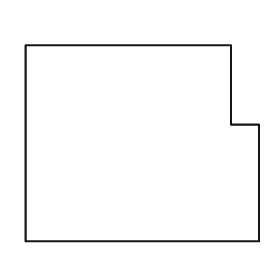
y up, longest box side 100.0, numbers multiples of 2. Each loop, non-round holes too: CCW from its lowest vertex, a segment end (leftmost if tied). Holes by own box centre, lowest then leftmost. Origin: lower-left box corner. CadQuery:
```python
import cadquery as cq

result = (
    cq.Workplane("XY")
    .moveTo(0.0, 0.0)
    .lineTo(100.0, 0.0)
    .lineTo(100.0, 50.0)
    .lineTo(88.0, 50.0)
    .lineTo(88.0, 84.0)
    .lineTo(0.0, 84.0)
    .close()
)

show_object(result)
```